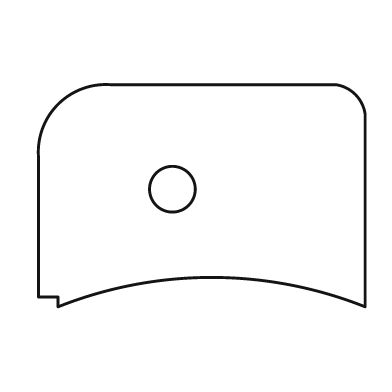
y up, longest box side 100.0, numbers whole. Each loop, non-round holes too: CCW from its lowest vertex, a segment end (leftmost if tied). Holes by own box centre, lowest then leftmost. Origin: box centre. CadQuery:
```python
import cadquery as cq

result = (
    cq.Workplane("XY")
    .moveTo(-44.0, -34.0)
    .threePointArc((3.0, -25.0), (50.0, -34.0))
    .lineTo(50.0, 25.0)
    .threePointArc((47.0, 31.0), (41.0, 34.0))
    .lineTo(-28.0, 34.0)
    .threePointArc((-44.0, 28.0), (-50.0, 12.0))
    .lineTo(-50.0, -31.0)
    .lineTo(-44.0, -31.0)
    .close()
    .moveTo(-9.0, 2.0)
    .circle(7.0)
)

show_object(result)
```